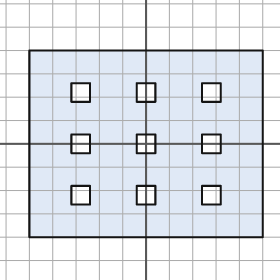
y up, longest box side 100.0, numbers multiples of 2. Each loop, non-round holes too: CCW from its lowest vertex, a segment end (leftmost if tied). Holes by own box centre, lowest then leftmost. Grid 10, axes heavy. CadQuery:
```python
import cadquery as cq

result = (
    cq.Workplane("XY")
    .moveTo(-50.0, -40.0)
    .lineTo(50.0, -40.0)
    .lineTo(50.0, 40.0)
    .lineTo(-50.0, 40.0)
    .close()
    .moveTo(-32.0, -26.0)
    .lineTo(-24.0, -26.0)
    .lineTo(-24.0, -18.0)
    .lineTo(-32.0, -18.0)
    .close()
    .moveTo(-4.0, -26.0)
    .lineTo(4.0, -26.0)
    .lineTo(4.0, -18.0)
    .lineTo(-4.0, -18.0)
    .close()
    .moveTo(24.0, -26.0)
    .lineTo(32.0, -26.0)
    .lineTo(32.0, -18.0)
    .lineTo(24.0, -18.0)
    .close()
    .moveTo(-32.0, -4.0)
    .lineTo(-24.0, -4.0)
    .lineTo(-24.0, 4.0)
    .lineTo(-32.0, 4.0)
    .close()
    .moveTo(-4.0, -4.0)
    .lineTo(4.0, -4.0)
    .lineTo(4.0, 4.0)
    .lineTo(-4.0, 4.0)
    .close()
    .moveTo(24.0, -4.0)
    .lineTo(32.0, -4.0)
    .lineTo(32.0, 4.0)
    .lineTo(24.0, 4.0)
    .close()
    .moveTo(-32.0, 18.0)
    .lineTo(-24.0, 18.0)
    .lineTo(-24.0, 26.0)
    .lineTo(-32.0, 26.0)
    .close()
    .moveTo(-4.0, 18.0)
    .lineTo(4.0, 18.0)
    .lineTo(4.0, 26.0)
    .lineTo(-4.0, 26.0)
    .close()
    .moveTo(24.0, 18.0)
    .lineTo(32.0, 18.0)
    .lineTo(32.0, 26.0)
    .lineTo(24.0, 26.0)
    .close()
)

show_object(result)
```